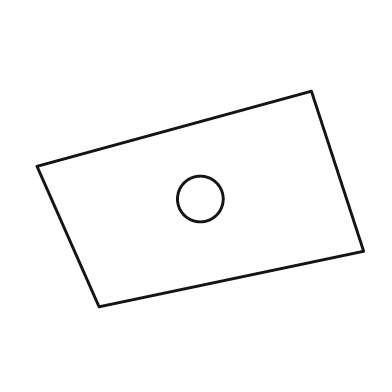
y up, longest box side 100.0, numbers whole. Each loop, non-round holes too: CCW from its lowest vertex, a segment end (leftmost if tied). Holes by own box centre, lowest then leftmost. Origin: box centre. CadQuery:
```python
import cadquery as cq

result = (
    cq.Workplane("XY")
    .moveTo(-31.0, -33.0)
    .lineTo(50.0, -16.0)
    .lineTo(34.0, 33.0)
    .lineTo(-50.0, 10.0)
    .close()
    .moveTo(0.0, 0.0)
    .circle(7.0)
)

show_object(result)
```